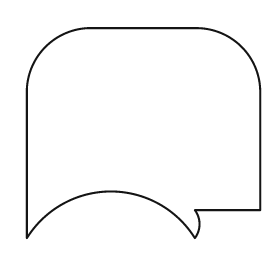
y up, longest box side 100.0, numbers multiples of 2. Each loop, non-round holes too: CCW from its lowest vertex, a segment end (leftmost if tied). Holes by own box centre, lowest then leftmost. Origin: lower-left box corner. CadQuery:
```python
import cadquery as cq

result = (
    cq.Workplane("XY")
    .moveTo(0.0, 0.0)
    .threePointArc((36.0, 20.0), (72.0, 0.0))
    .threePointArc((74.0, 6.0), (72.0, 12.0))
    .lineTo(100.0, 12.0)
    .lineTo(100.0, 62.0)
    .threePointArc((92.0, 82.0), (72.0, 90.0))
    .lineTo(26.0, 90.0)
    .threePointArc((8.0, 82.0), (0.0, 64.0))
    .close()
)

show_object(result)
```